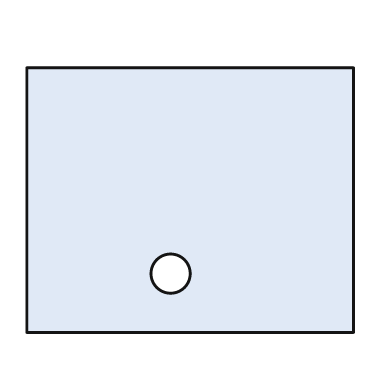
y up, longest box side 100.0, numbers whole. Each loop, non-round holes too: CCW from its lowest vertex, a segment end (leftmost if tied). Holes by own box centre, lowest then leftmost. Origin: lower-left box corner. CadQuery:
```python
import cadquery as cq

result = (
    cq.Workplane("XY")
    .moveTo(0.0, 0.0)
    .lineTo(100.0, 0.0)
    .lineTo(100.0, 81.0)
    .lineTo(0.0, 81.0)
    .close()
    .moveTo(44.0, 18.0)
    .circle(6.0)
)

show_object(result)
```